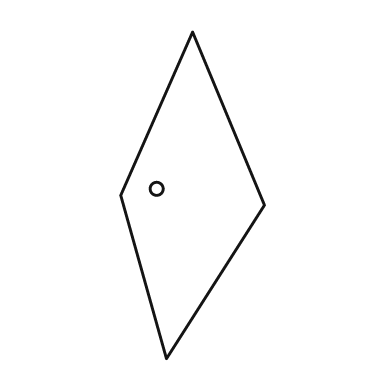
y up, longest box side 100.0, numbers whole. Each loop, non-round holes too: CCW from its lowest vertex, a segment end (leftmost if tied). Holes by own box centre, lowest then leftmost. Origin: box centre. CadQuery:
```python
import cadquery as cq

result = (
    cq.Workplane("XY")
    .moveTo(-8.0, -50.0)
    .lineTo(22.0, -3.0)
    .lineTo(0.0, 50.0)
    .lineTo(-22.0, 0.0)
    .close()
    .moveTo(-11.0, 2.0)
    .circle(2.0)
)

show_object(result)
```